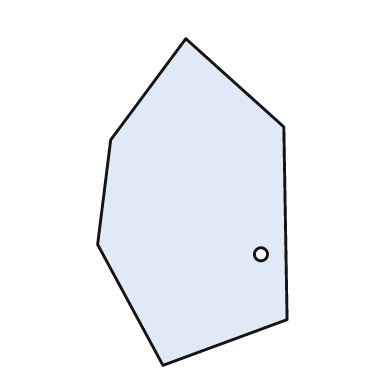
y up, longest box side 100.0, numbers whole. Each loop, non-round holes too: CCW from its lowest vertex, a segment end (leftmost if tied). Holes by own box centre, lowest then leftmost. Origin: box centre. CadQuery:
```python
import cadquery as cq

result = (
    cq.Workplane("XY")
    .moveTo(-9.0, -50.0)
    .lineTo(29.0, -36.0)
    .lineTo(28.0, 23.0)
    .lineTo(-2.0, 50.0)
    .lineTo(-25.0, 19.0)
    .lineTo(-29.0, -13.0)
    .close()
    .moveTo(21.0, -16.0)
    .circle(2.0)
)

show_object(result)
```